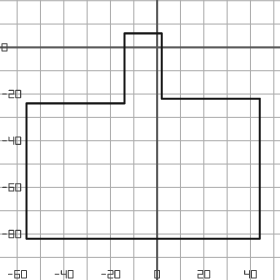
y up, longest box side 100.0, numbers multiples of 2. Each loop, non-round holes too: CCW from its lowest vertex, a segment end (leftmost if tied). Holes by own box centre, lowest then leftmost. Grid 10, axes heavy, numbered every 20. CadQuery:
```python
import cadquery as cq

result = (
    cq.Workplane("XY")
    .moveTo(-56.0, -82.0)
    .lineTo(44.0, -82.0)
    .lineTo(44.0, -22.0)
    .lineTo(2.0, -22.0)
    .lineTo(2.0, 6.0)
    .lineTo(-14.0, 6.0)
    .lineTo(-14.0, -24.0)
    .lineTo(-56.0, -24.0)
    .close()
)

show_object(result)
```